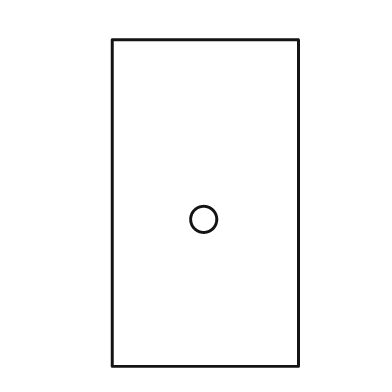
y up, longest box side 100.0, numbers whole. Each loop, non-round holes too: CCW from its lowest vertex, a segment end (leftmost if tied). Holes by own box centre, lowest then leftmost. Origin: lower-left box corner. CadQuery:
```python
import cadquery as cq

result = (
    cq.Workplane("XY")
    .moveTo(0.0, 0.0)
    .lineTo(57.0, 0.0)
    .lineTo(57.0, 100.0)
    .lineTo(0.0, 100.0)
    .close()
    .moveTo(28.0, 45.0)
    .circle(4.0)
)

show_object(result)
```